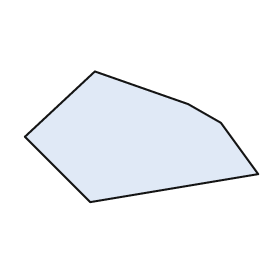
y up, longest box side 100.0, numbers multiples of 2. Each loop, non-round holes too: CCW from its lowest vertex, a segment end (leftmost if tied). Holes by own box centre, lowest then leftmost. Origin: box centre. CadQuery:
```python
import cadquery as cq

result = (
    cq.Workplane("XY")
    .moveTo(-22.0, -28.0)
    .lineTo(50.0, -16.0)
    .lineTo(34.0, 6.0)
    .lineTo(20.0, 14.0)
    .lineTo(-20.0, 28.0)
    .lineTo(-50.0, 0.0)
    .close()
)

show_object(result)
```